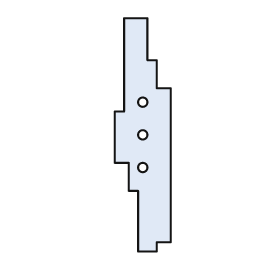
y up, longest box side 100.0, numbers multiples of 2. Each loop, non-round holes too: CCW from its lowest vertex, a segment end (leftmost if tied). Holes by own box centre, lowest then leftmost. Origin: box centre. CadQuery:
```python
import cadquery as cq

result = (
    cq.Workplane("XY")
    .moveTo(-2.0, -50.0)
    .lineTo(6.0, -50.0)
    .lineTo(6.0, -46.0)
    .lineTo(12.0, -46.0)
    .lineTo(12.0, 20.0)
    .lineTo(6.0, 20.0)
    .lineTo(6.0, 32.0)
    .lineTo(2.0, 32.0)
    .lineTo(2.0, 50.0)
    .lineTo(-8.0, 50.0)
    .lineTo(-8.0, 10.0)
    .lineTo(-12.0, 10.0)
    .lineTo(-12.0, -12.0)
    .lineTo(-6.0, -12.0)
    .lineTo(-6.0, -24.0)
    .lineTo(-2.0, -24.0)
    .close()
    .moveTo(0.0, -14.0)
    .circle(2.0)
    .moveTo(0.0, 0.0)
    .circle(2.0)
    .moveTo(0.0, 14.0)
    .circle(2.0)
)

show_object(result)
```